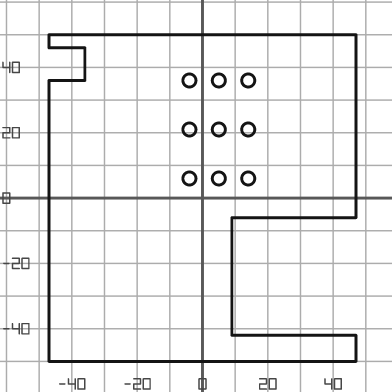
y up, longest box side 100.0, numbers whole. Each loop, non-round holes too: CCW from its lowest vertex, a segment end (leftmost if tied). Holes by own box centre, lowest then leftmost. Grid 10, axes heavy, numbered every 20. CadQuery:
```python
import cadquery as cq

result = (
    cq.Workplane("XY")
    .moveTo(-47.0, -50.0)
    .lineTo(47.0, -50.0)
    .lineTo(47.0, -42.0)
    .lineTo(9.0, -42.0)
    .lineTo(9.0, -6.0)
    .lineTo(47.0, -6.0)
    .lineTo(47.0, 50.0)
    .lineTo(-47.0, 50.0)
    .lineTo(-47.0, 46.0)
    .lineTo(-36.0, 46.0)
    .lineTo(-36.0, 36.0)
    .lineTo(-47.0, 36.0)
    .close()
    .moveTo(-4.0, 6.0)
    .circle(2.0)
    .moveTo(5.0, 6.0)
    .circle(2.0)
    .moveTo(14.0, 6.0)
    .circle(2.0)
    .moveTo(-4.0, 21.0)
    .circle(2.0)
    .moveTo(5.0, 21.0)
    .circle(2.0)
    .moveTo(14.0, 21.0)
    .circle(2.0)
    .moveTo(-4.0, 36.0)
    .circle(2.0)
    .moveTo(5.0, 36.0)
    .circle(2.0)
    .moveTo(14.0, 36.0)
    .circle(2.0)
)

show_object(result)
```